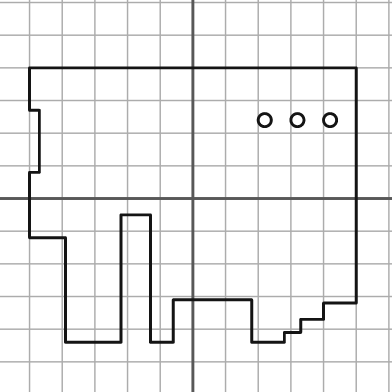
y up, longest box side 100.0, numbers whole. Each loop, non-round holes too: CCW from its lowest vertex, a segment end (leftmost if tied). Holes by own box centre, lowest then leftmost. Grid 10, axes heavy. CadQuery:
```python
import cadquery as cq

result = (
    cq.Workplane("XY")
    .moveTo(-39.0, -44.0)
    .lineTo(-22.0, -44.0)
    .lineTo(-22.0, -5.0)
    .lineTo(-13.0, -5.0)
    .lineTo(-13.0, -44.0)
    .lineTo(-6.0, -44.0)
    .lineTo(-6.0, -31.0)
    .lineTo(18.0, -31.0)
    .lineTo(18.0, -44.0)
    .lineTo(28.0, -44.0)
    .lineTo(28.0, -41.0)
    .lineTo(33.0, -41.0)
    .lineTo(33.0, -37.0)
    .lineTo(40.0, -37.0)
    .lineTo(40.0, -32.0)
    .lineTo(50.0, -32.0)
    .lineTo(50.0, 40.0)
    .lineTo(-50.0, 40.0)
    .lineTo(-50.0, 27.0)
    .lineTo(-47.0, 27.0)
    .lineTo(-47.0, 8.0)
    .lineTo(-50.0, 8.0)
    .lineTo(-50.0, -12.0)
    .lineTo(-39.0, -12.0)
    .close()
    .moveTo(22.0, 24.0)
    .circle(2.0)
    .moveTo(32.0, 24.0)
    .circle(2.0)
    .moveTo(42.0, 24.0)
    .circle(2.0)
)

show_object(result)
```